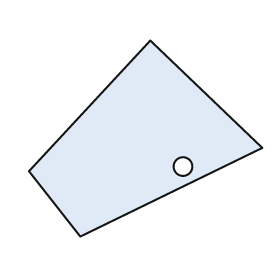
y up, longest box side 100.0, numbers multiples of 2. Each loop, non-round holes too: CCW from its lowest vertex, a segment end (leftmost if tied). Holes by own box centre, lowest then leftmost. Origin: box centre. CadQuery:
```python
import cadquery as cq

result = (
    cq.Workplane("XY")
    .moveTo(-28.0, -42.0)
    .lineTo(50.0, -4.0)
    .lineTo(2.0, 42.0)
    .lineTo(-50.0, -14.0)
    .close()
    .moveTo(16.0, -12.0)
    .circle(4.0)
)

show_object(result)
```